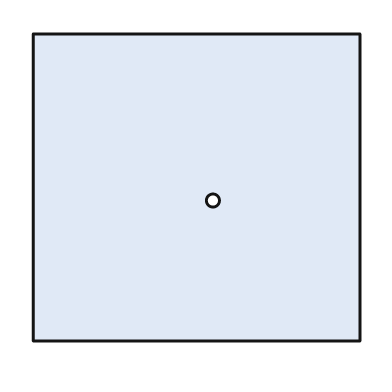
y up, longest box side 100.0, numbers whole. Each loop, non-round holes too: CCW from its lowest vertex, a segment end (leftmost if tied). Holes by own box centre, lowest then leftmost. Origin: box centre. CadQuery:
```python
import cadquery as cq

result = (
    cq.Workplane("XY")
    .moveTo(-50.0, -47.0)
    .lineTo(50.0, -47.0)
    .lineTo(50.0, 47.0)
    .lineTo(-50.0, 47.0)
    .close()
    .moveTo(5.0, -4.0)
    .circle(2.0)
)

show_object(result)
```